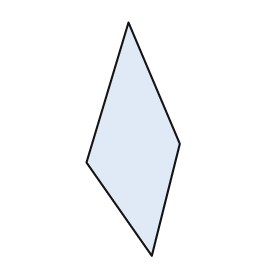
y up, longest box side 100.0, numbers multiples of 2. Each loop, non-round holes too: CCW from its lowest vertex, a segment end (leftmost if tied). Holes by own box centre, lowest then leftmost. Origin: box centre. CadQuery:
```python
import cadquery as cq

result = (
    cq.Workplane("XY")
    .moveTo(8.0, -50.0)
    .lineTo(20.0, -2.0)
    .lineTo(-2.0, 50.0)
    .lineTo(-20.0, -10.0)
    .close()
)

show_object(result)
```